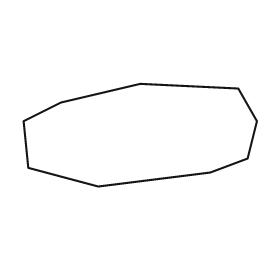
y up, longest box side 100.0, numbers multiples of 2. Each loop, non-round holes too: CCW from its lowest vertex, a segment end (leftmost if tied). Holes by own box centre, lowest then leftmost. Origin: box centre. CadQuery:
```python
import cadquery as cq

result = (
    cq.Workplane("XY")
    .moveTo(-18.0, -22.0)
    .lineTo(30.0, -16.0)
    .lineTo(46.0, -10.0)
    .lineTo(50.0, 6.0)
    .lineTo(42.0, 20.0)
    .lineTo(0.0, 22.0)
    .lineTo(-34.0, 14.0)
    .lineTo(-50.0, 6.0)
    .lineTo(-48.0, -14.0)
    .close()
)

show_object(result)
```